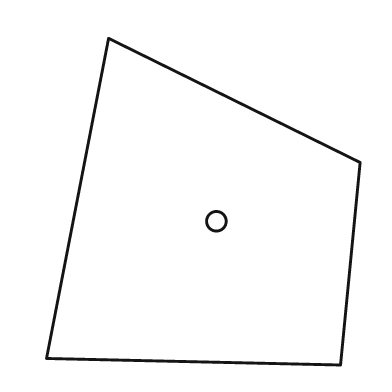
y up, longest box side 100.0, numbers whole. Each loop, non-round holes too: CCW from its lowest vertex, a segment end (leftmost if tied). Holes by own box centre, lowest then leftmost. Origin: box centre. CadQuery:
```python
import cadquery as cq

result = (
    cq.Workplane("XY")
    .moveTo(42.0, -50.0)
    .lineTo(48.0, 12.0)
    .lineTo(-29.0, 50.0)
    .lineTo(-48.0, -48.0)
    .close()
    .moveTo(4.0, -6.0)
    .circle(3.0)
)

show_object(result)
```